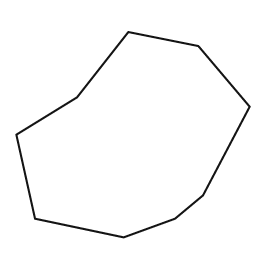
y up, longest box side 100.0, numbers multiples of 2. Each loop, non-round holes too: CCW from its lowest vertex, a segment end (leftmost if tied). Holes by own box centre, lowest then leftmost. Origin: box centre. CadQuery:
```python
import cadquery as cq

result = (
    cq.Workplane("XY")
    .moveTo(-4.0, -44.0)
    .lineTo(18.0, -36.0)
    .lineTo(30.0, -26.0)
    .lineTo(50.0, 12.0)
    .lineTo(28.0, 38.0)
    .lineTo(-2.0, 44.0)
    .lineTo(-24.0, 16.0)
    .lineTo(-50.0, 0.0)
    .lineTo(-42.0, -36.0)
    .close()
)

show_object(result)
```